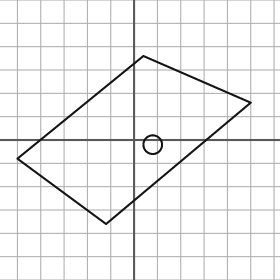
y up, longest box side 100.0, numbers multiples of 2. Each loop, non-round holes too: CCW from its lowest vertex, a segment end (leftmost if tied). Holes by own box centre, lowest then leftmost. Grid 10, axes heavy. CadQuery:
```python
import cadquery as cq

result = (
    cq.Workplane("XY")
    .moveTo(-12.0, -36.0)
    .lineTo(50.0, 16.0)
    .lineTo(4.0, 36.0)
    .lineTo(-50.0, -8.0)
    .close()
    .moveTo(8.0, -2.0)
    .circle(4.0)
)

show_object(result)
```